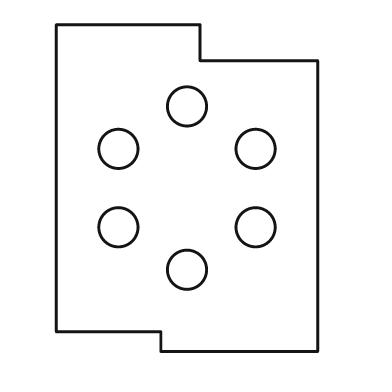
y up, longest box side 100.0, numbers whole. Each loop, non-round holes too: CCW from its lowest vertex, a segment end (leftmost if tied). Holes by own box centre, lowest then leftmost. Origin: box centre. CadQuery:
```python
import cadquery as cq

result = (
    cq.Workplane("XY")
    .moveTo(-8.0, -50.0)
    .lineTo(40.0, -50.0)
    .lineTo(40.0, 39.0)
    .lineTo(4.0, 39.0)
    .lineTo(4.0, 50.0)
    .lineTo(-40.0, 50.0)
    .lineTo(-40.0, -44.0)
    .lineTo(-8.0, -44.0)
    .close()
    .moveTo(0.0, -25.0)
    .circle(6.0)
    .moveTo(-21.0, -12.0)
    .circle(6.0)
    .moveTo(21.0, -12.0)
    .circle(6.0)
    .moveTo(-21.0, 12.0)
    .circle(6.0)
    .moveTo(21.0, 12.0)
    .circle(6.0)
    .moveTo(0.0, 25.0)
    .circle(6.0)
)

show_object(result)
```